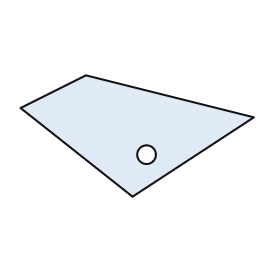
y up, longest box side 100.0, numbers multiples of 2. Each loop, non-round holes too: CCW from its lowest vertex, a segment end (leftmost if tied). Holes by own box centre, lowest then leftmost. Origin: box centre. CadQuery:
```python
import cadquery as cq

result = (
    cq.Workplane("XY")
    .moveTo(-2.0, -26.0)
    .lineTo(50.0, 8.0)
    .lineTo(-22.0, 26.0)
    .lineTo(-50.0, 12.0)
    .close()
    .moveTo(4.0, -8.0)
    .circle(4.0)
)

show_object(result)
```